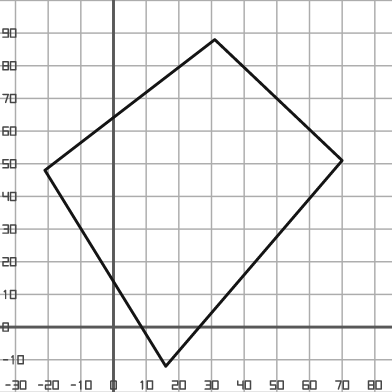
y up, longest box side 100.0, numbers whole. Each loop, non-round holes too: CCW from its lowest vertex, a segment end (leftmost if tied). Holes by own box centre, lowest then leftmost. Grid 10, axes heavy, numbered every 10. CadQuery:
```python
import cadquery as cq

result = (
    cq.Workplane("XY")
    .moveTo(16.0, -12.0)
    .lineTo(70.0, 51.0)
    .lineTo(31.0, 88.0)
    .lineTo(-21.0, 48.0)
    .close()
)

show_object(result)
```